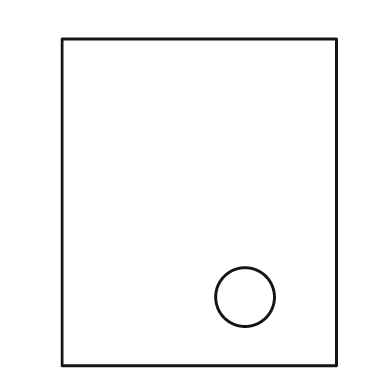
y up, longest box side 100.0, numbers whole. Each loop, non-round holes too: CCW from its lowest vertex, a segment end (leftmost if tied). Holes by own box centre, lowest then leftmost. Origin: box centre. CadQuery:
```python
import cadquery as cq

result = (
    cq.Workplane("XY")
    .moveTo(-42.0, -50.0)
    .lineTo(42.0, -50.0)
    .lineTo(42.0, 50.0)
    .lineTo(-42.0, 50.0)
    .close()
    .moveTo(14.0, -29.0)
    .circle(9.0)
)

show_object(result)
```